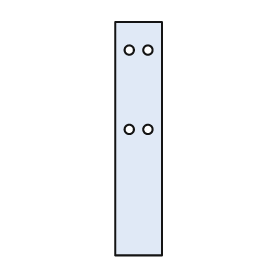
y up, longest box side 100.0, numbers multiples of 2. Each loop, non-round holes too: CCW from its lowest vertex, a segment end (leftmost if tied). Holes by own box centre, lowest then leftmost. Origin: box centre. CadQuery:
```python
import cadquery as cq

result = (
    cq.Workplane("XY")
    .moveTo(-10.0, -50.0)
    .lineTo(10.0, -50.0)
    .lineTo(10.0, 50.0)
    .lineTo(-10.0, 50.0)
    .close()
    .moveTo(-4.0, 4.0)
    .circle(2.0)
    .moveTo(4.0, 4.0)
    .circle(2.0)
    .moveTo(-4.0, 38.0)
    .circle(2.0)
    .moveTo(4.0, 38.0)
    .circle(2.0)
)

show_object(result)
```